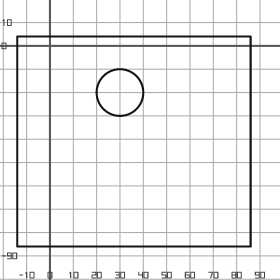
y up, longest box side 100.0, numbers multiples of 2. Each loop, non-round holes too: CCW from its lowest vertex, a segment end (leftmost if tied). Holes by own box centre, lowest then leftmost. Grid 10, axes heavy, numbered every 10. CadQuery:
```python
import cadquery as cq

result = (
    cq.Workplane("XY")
    .moveTo(-14.0, -86.0)
    .lineTo(86.0, -86.0)
    .lineTo(86.0, 4.0)
    .lineTo(-14.0, 4.0)
    .close()
    .moveTo(30.0, -20.0)
    .circle(10.0)
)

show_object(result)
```